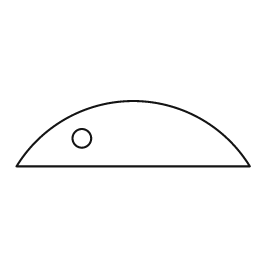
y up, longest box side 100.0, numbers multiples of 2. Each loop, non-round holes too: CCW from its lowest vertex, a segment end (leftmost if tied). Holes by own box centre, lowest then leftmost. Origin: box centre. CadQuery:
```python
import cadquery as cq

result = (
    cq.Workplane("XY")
    .moveTo(-50.0, -14.0)
    .lineTo(50.0, -14.0)
    .threePointArc((0.0, 14.0), (-50.0, -14.0))
    .close()
    .moveTo(-22.0, -2.0)
    .circle(4.0)
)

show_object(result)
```